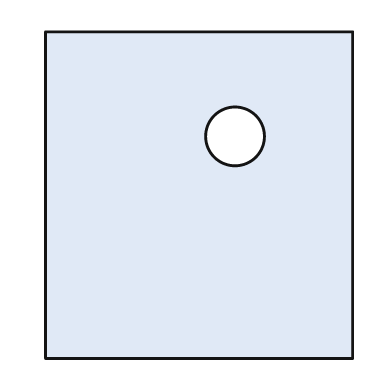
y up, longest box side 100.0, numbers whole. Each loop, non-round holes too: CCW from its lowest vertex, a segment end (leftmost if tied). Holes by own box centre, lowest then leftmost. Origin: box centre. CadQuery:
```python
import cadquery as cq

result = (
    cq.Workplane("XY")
    .moveTo(-47.0, -50.0)
    .lineTo(47.0, -50.0)
    .lineTo(47.0, 50.0)
    .lineTo(-47.0, 50.0)
    .close()
    .moveTo(11.0, 18.0)
    .circle(9.0)
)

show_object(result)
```